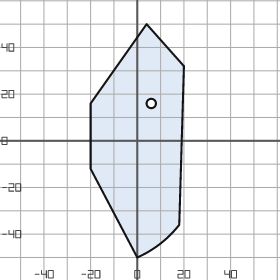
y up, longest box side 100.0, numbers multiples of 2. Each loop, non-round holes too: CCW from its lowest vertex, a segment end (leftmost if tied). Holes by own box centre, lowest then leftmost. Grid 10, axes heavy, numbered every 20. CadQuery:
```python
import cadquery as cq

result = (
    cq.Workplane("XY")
    .moveTo(0.0, -50.0)
    .threePointArc((10.0, -44.0), (18.0, -36.0))
    .lineTo(20.0, 32.0)
    .lineTo(4.0, 50.0)
    .lineTo(-20.0, 16.0)
    .lineTo(-20.0, -12.0)
    .close()
    .moveTo(6.0, 16.0)
    .circle(2.0)
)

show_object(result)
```